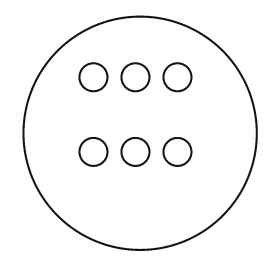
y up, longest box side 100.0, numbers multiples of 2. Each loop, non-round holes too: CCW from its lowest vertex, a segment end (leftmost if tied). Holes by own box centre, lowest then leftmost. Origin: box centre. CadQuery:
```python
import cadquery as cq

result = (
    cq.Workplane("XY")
    .moveTo(0.0, 0.0)
    .circle(50.0)
    .moveTo(-20.0, -8.0)
    .circle(6.0)
    .moveTo(-2.0, -8.0)
    .circle(6.0)
    .moveTo(16.0, -8.0)
    .circle(6.0)
    .moveTo(-20.0, 24.0)
    .circle(6.0)
    .moveTo(-2.0, 24.0)
    .circle(6.0)
    .moveTo(16.0, 24.0)
    .circle(6.0)
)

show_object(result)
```